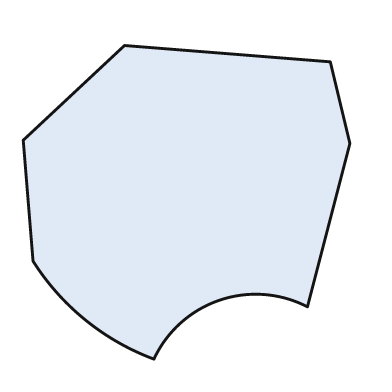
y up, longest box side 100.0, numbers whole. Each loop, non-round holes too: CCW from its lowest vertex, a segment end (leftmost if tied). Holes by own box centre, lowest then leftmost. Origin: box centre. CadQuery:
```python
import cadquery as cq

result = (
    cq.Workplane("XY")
    .moveTo(-10.0, -48.0)
    .threePointArc((10.0, -30.0), (37.0, -32.0))
    .lineTo(50.0, 18.0)
    .lineTo(44.0, 43.0)
    .lineTo(-19.0, 48.0)
    .lineTo(-50.0, 19.0)
    .lineTo(-47.0, -18.0)
    .threePointArc((-31.0, -36.0), (-10.0, -48.0))
    .close()
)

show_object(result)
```